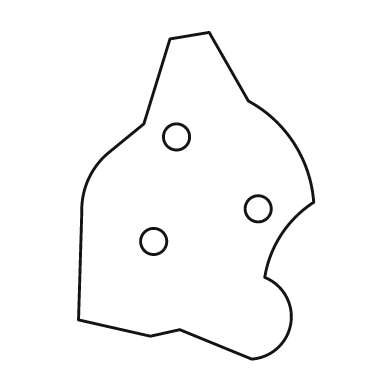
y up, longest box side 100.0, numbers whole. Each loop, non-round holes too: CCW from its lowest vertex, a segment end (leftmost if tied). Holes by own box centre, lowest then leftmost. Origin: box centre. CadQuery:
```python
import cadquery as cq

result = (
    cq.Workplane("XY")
    .moveTo(17.0, -50.0)
    .threePointArc((29.0, -39.0), (21.0, -25.0))
    .threePointArc((26.0, -12.0), (36.0, -2.0))
    .threePointArc((30.0, 16.0), (16.0, 29.0))
    .lineTo(4.0, 50.0)
    .lineTo(-8.0, 48.0)
    .lineTo(-16.0, 22.0)
    .lineTo(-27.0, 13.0)
    .threePointArc((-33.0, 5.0), (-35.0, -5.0))
    .lineTo(-36.0, -38.0)
    .lineTo(-14.0, -43.0)
    .lineTo(-5.0, -41.0)
    .close()
    .moveTo(-13.0, -14.0)
    .circle(4.0)
    .moveTo(19.0, -4.0)
    .circle(4.0)
    .moveTo(-6.0, 18.0)
    .circle(4.0)
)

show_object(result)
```